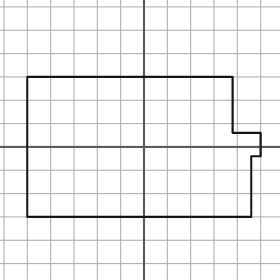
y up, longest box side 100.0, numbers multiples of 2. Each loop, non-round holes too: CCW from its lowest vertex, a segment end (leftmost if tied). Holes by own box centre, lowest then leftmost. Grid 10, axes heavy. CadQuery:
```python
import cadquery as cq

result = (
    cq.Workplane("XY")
    .moveTo(-50.0, -30.0)
    .lineTo(46.0, -30.0)
    .lineTo(46.0, -4.0)
    .lineTo(50.0, -4.0)
    .lineTo(50.0, 6.0)
    .lineTo(38.0, 6.0)
    .lineTo(38.0, 30.0)
    .lineTo(-50.0, 30.0)
    .close()
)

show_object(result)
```